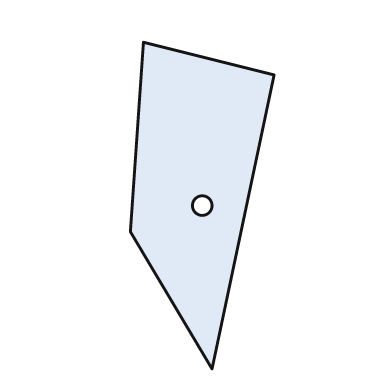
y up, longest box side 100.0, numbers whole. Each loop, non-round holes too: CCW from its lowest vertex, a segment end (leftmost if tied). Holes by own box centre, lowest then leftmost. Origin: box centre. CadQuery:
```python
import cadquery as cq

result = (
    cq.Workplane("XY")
    .moveTo(3.0, -50.0)
    .lineTo(22.0, 40.0)
    .lineTo(-18.0, 50.0)
    .lineTo(-22.0, -8.0)
    .close()
    .moveTo(0.0, 0.0)
    .circle(3.0)
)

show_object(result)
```